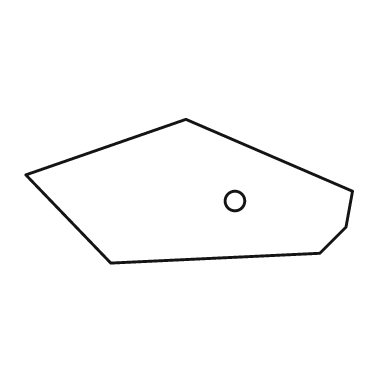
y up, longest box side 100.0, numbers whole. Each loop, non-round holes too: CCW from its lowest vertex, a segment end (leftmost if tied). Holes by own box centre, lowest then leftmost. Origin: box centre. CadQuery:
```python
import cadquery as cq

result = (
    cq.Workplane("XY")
    .moveTo(-24.0, -22.0)
    .lineTo(40.0, -19.0)
    .lineTo(48.0, -11.0)
    .lineTo(50.0, 0.0)
    .lineTo(-1.0, 22.0)
    .lineTo(-50.0, 5.0)
    .close()
    .moveTo(14.0, -3.0)
    .circle(3.0)
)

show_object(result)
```